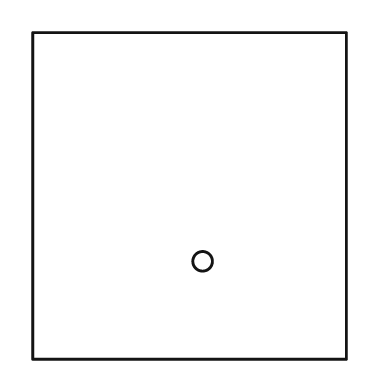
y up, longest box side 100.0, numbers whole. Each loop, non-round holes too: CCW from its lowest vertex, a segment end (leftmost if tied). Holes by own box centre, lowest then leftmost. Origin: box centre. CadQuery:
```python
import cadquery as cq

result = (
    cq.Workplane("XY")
    .moveTo(-48.0, -50.0)
    .lineTo(48.0, -50.0)
    .lineTo(48.0, 50.0)
    .lineTo(-48.0, 50.0)
    .close()
    .moveTo(4.0, -20.0)
    .circle(3.0)
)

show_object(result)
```